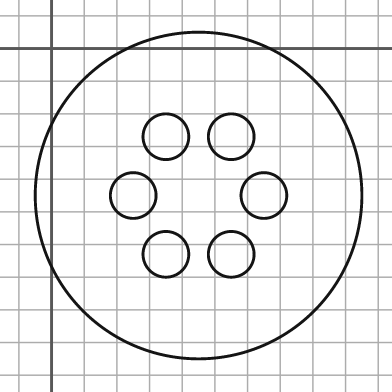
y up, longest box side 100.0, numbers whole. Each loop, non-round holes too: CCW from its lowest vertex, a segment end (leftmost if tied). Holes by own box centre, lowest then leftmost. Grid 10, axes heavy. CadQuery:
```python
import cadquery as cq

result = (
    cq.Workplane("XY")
    .moveTo(45.0, -45.0)
    .circle(50.0)
    .moveTo(35.0, -63.0)
    .circle(7.0)
    .moveTo(55.0, -63.0)
    .circle(7.0)
    .moveTo(25.0, -45.0)
    .circle(7.0)
    .moveTo(65.0, -45.0)
    .circle(7.0)
    .moveTo(35.0, -27.0)
    .circle(7.0)
    .moveTo(55.0, -27.0)
    .circle(7.0)
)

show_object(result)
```